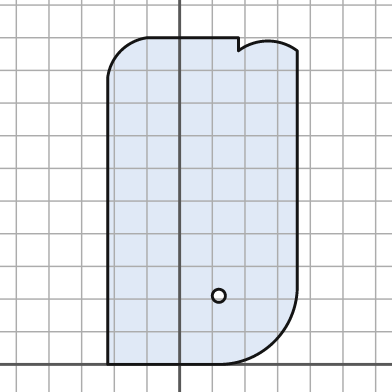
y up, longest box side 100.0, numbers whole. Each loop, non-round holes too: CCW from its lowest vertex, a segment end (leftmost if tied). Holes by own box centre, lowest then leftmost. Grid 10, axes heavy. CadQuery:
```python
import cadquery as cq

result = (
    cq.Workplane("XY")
    .moveTo(-22.0, 0.0)
    .lineTo(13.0, 0.0)
    .threePointArc((29.0, 7.0), (36.0, 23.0))
    .lineTo(36.0, 96.0)
    .threePointArc((27.0, 99.0), (18.0, 96.0))
    .lineTo(18.0, 100.0)
    .lineTo(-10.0, 100.0)
    .threePointArc((-18.0, 96.0), (-22.0, 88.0))
    .close()
    .moveTo(12.0, 21.0)
    .circle(2.0)
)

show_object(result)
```